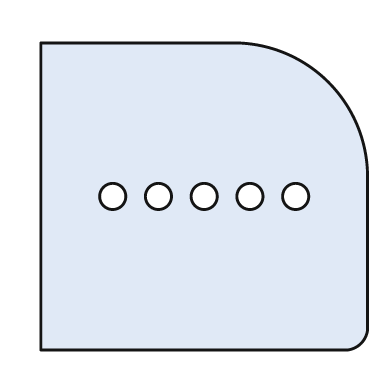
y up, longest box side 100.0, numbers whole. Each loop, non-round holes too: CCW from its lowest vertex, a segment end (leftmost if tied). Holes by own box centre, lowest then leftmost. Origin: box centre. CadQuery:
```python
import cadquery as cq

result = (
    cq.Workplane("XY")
    .moveTo(-50.0, -47.0)
    .lineTo(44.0, -47.0)
    .threePointArc((48.0, -45.0), (50.0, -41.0))
    .lineTo(50.0, 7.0)
    .threePointArc((38.0, 35.0), (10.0, 47.0))
    .lineTo(-50.0, 47.0)
    .close()
    .moveTo(-28.0, 0.0)
    .circle(4.0)
    .moveTo(-14.0, 0.0)
    .circle(4.0)
    .moveTo(0.0, 0.0)
    .circle(4.0)
    .moveTo(14.0, 0.0)
    .circle(4.0)
    .moveTo(28.0, 0.0)
    .circle(4.0)
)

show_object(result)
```